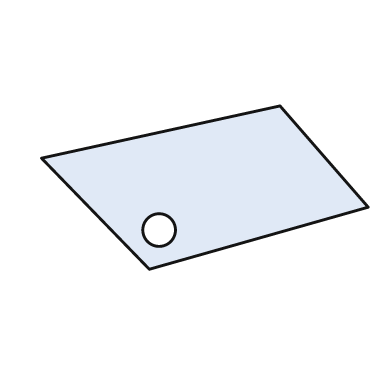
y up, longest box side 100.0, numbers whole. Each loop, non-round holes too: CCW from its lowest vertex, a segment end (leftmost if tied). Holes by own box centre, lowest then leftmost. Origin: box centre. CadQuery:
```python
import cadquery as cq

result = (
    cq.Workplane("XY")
    .moveTo(-17.0, -25.0)
    .lineTo(50.0, -6.0)
    .lineTo(23.0, 25.0)
    .lineTo(-50.0, 9.0)
    .close()
    .moveTo(-14.0, -13.0)
    .circle(5.0)
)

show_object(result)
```